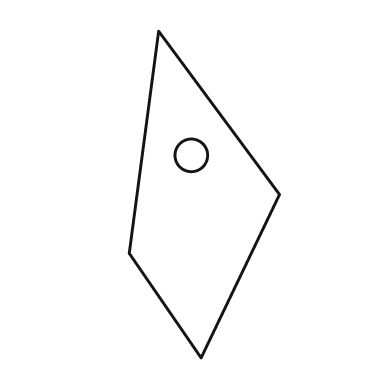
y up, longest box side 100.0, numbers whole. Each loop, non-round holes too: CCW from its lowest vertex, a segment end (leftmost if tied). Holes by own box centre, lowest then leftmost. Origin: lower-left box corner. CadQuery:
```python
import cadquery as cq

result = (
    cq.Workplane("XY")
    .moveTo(22.0, 0.0)
    .lineTo(46.0, 50.0)
    .lineTo(9.0, 100.0)
    .lineTo(0.0, 32.0)
    .close()
    .moveTo(19.0, 62.0)
    .circle(5.0)
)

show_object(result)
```